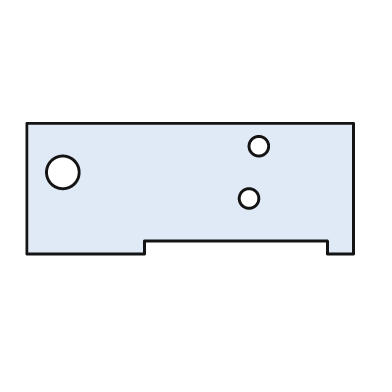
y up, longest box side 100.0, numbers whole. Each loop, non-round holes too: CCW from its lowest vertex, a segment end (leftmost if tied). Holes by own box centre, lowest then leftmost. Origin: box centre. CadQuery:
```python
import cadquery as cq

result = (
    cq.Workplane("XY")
    .moveTo(-50.0, -20.0)
    .lineTo(-14.0, -20.0)
    .lineTo(-14.0, -16.0)
    .lineTo(42.0, -16.0)
    .lineTo(42.0, -20.0)
    .lineTo(50.0, -20.0)
    .lineTo(50.0, 20.0)
    .lineTo(-50.0, 20.0)
    .close()
    .moveTo(18.0, -3.0)
    .circle(3.0)
    .moveTo(-39.0, 5.0)
    .circle(5.0)
    .moveTo(21.0, 13.0)
    .circle(3.0)
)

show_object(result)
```